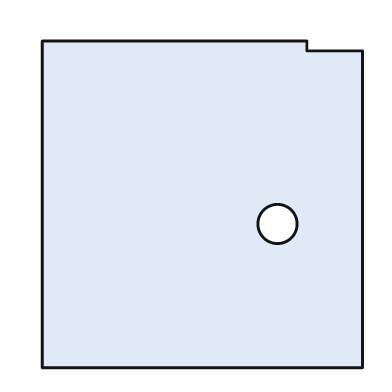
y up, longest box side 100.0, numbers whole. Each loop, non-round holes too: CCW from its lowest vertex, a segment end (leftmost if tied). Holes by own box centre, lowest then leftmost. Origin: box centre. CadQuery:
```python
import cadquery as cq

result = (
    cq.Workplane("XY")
    .moveTo(-49.0, -50.0)
    .lineTo(49.0, -50.0)
    .lineTo(49.0, 47.0)
    .lineTo(32.0, 47.0)
    .lineTo(32.0, 50.0)
    .lineTo(-49.0, 50.0)
    .close()
    .moveTo(23.0, -6.0)
    .circle(6.0)
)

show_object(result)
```